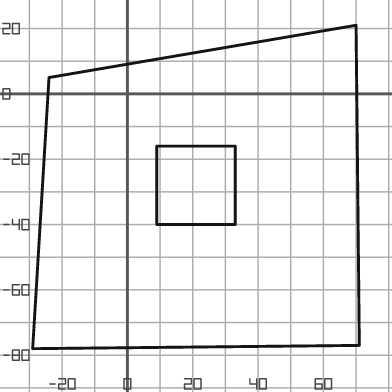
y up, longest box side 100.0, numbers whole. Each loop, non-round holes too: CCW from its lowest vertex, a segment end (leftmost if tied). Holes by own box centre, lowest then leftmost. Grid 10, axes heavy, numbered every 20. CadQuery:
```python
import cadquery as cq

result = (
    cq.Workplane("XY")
    .moveTo(-29.0, -78.0)
    .lineTo(71.0, -77.0)
    .lineTo(70.0, 21.0)
    .lineTo(-24.0, 5.0)
    .close()
    .moveTo(9.0, -40.0)
    .lineTo(33.0, -40.0)
    .lineTo(33.0, -16.0)
    .lineTo(9.0, -16.0)
    .close()
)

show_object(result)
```